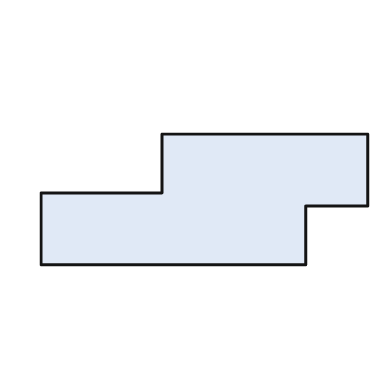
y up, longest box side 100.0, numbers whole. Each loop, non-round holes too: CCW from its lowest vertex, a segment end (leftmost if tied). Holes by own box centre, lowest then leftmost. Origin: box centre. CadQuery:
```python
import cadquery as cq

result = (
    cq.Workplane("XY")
    .moveTo(-50.0, -20.0)
    .lineTo(31.0, -20.0)
    .lineTo(31.0, -2.0)
    .lineTo(50.0, -2.0)
    .lineTo(50.0, 20.0)
    .lineTo(-13.0, 20.0)
    .lineTo(-13.0, 2.0)
    .lineTo(-50.0, 2.0)
    .close()
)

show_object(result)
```